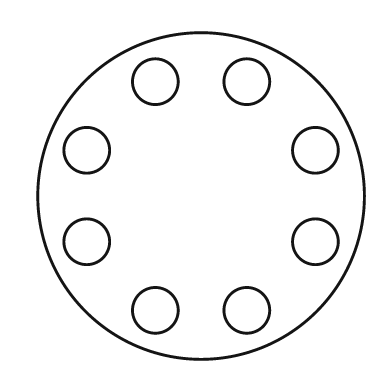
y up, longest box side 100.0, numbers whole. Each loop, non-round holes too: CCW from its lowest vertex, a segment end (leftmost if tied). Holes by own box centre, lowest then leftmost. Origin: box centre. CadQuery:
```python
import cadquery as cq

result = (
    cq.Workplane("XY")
    .moveTo(0.0, 0.0)
    .circle(50.0)
    .moveTo(-14.0, -35.0)
    .circle(7.0)
    .moveTo(14.0, -35.0)
    .circle(7.0)
    .moveTo(-35.0, -14.0)
    .circle(7.0)
    .moveTo(35.0, -14.0)
    .circle(7.0)
    .moveTo(-35.0, 14.0)
    .circle(7.0)
    .moveTo(35.0, 14.0)
    .circle(7.0)
    .moveTo(-14.0, 35.0)
    .circle(7.0)
    .moveTo(14.0, 35.0)
    .circle(7.0)
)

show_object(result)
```